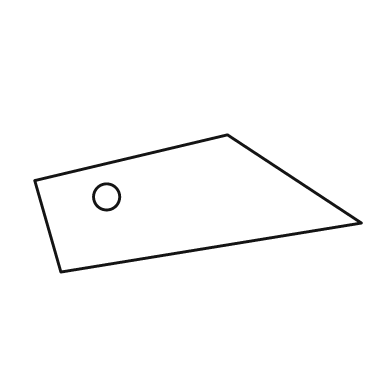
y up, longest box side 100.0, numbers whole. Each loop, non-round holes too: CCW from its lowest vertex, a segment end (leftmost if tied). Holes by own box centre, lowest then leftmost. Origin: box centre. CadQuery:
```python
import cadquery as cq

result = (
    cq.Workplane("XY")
    .moveTo(-42.0, -21.0)
    .lineTo(50.0, -6.0)
    .lineTo(9.0, 21.0)
    .lineTo(-50.0, 7.0)
    .close()
    .moveTo(-28.0, 2.0)
    .circle(4.0)
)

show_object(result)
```